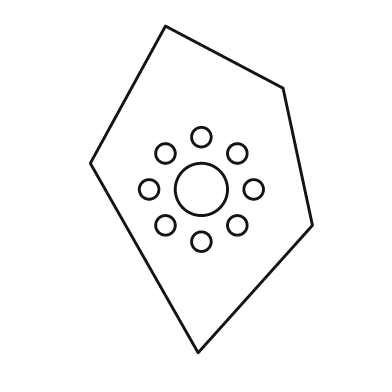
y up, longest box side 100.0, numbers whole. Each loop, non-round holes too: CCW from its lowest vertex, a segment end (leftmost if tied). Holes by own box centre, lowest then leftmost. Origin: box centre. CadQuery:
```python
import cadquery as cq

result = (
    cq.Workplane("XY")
    .moveTo(-1.0, -50.0)
    .lineTo(34.0, -11.0)
    .lineTo(25.0, 31.0)
    .lineTo(-11.0, 50.0)
    .lineTo(-34.0, 8.0)
    .close()
    .moveTo(0.0, -16.0)
    .circle(3.0)
    .moveTo(-11.0, -11.0)
    .circle(3.0)
    .moveTo(11.0, -11.0)
    .circle(3.0)
    .moveTo(-16.0, 0.0)
    .circle(3.0)
    .moveTo(0.0, 0.0)
    .circle(8.0)
    .moveTo(16.0, 0.0)
    .circle(3.0)
    .moveTo(-11.0, 11.0)
    .circle(3.0)
    .moveTo(11.0, 11.0)
    .circle(3.0)
    .moveTo(0.0, 16.0)
    .circle(3.0)
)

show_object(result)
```